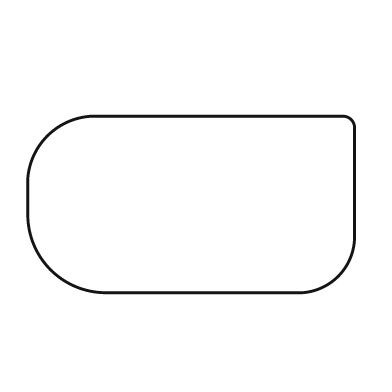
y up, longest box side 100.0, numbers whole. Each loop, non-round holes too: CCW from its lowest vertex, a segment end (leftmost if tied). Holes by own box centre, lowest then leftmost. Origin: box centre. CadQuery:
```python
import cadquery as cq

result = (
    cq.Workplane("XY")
    .moveTo(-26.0, -27.0)
    .lineTo(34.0, -27.0)
    .threePointArc((45.0, -22.0), (50.0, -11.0))
    .lineTo(50.0, 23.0)
    .threePointArc((49.0, 26.0), (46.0, 27.0))
    .lineTo(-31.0, 27.0)
    .threePointArc((-44.0, 21.0), (-50.0, 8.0))
    .lineTo(-50.0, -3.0)
    .threePointArc((-43.0, -20.0), (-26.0, -27.0))
    .close()
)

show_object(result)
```